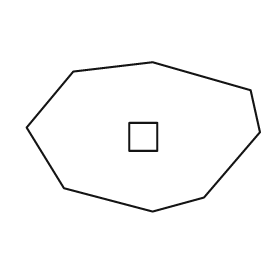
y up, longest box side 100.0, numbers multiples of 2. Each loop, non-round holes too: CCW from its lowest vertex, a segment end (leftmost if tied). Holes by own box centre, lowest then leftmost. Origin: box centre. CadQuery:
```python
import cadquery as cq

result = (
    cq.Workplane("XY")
    .moveTo(4.0, -32.0)
    .lineTo(26.0, -26.0)
    .lineTo(50.0, 2.0)
    .lineTo(46.0, 20.0)
    .lineTo(4.0, 32.0)
    .lineTo(-30.0, 28.0)
    .lineTo(-50.0, 4.0)
    .lineTo(-34.0, -22.0)
    .close()
    .moveTo(-6.0, -6.0)
    .lineTo(6.0, -6.0)
    .lineTo(6.0, 6.0)
    .lineTo(-6.0, 6.0)
    .close()
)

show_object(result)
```